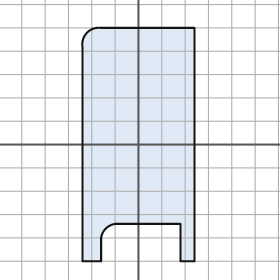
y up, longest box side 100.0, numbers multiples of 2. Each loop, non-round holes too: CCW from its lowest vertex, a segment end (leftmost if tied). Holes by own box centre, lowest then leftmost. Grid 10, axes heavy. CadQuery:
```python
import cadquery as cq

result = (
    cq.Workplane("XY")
    .moveTo(-24.0, -50.0)
    .lineTo(-16.0, -50.0)
    .lineTo(-16.0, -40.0)
    .threePointArc((-14.0, -36.0), (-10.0, -34.0))
    .lineTo(18.0, -34.0)
    .lineTo(18.0, -50.0)
    .lineTo(24.0, -50.0)
    .lineTo(24.0, 50.0)
    .lineTo(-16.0, 50.0)
    .threePointArc((-22.0, 48.0), (-24.0, 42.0))
    .close()
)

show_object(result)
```